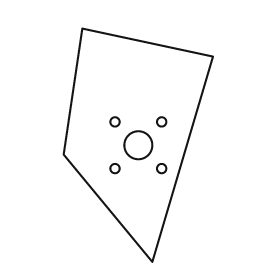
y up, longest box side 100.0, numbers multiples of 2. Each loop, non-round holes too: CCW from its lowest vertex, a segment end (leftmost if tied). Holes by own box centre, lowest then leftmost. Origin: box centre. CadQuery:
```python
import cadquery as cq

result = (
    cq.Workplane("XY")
    .moveTo(6.0, -50.0)
    .lineTo(32.0, 38.0)
    .lineTo(-24.0, 50.0)
    .lineTo(-32.0, -4.0)
    .close()
    .moveTo(-10.0, -10.0)
    .circle(2.0)
    .moveTo(10.0, -10.0)
    .circle(2.0)
    .moveTo(0.0, 0.0)
    .circle(6.0)
    .moveTo(-10.0, 10.0)
    .circle(2.0)
    .moveTo(10.0, 10.0)
    .circle(2.0)
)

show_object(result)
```